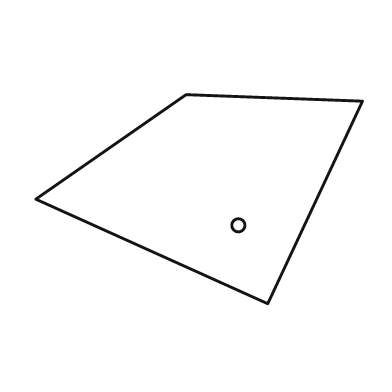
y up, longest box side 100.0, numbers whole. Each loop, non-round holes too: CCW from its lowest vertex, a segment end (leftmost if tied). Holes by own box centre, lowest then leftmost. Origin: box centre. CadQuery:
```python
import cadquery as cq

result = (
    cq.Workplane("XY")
    .moveTo(21.0, -32.0)
    .lineTo(50.0, 30.0)
    .lineTo(-4.0, 32.0)
    .lineTo(-50.0, 0.0)
    .close()
    .moveTo(12.0, -8.0)
    .circle(2.0)
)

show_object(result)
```